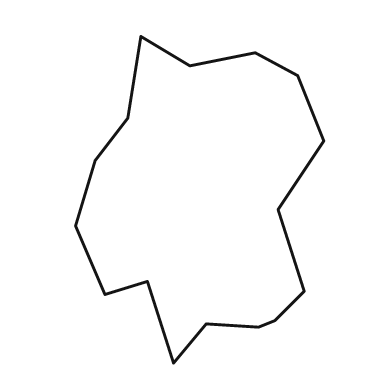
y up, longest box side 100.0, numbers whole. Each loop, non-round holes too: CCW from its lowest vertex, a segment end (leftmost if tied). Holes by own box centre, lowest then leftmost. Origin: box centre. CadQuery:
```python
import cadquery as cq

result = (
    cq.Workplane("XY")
    .moveTo(-8.0, -50.0)
    .lineTo(2.0, -38.0)
    .lineTo(18.0, -39.0)
    .lineTo(23.0, -37.0)
    .lineTo(32.0, -28.0)
    .lineTo(24.0, -3.0)
    .lineTo(38.0, 18.0)
    .lineTo(30.0, 38.0)
    .lineTo(17.0, 45.0)
    .lineTo(-3.0, 41.0)
    .lineTo(-18.0, 50.0)
    .lineTo(-22.0, 25.0)
    .lineTo(-32.0, 12.0)
    .lineTo(-38.0, -8.0)
    .lineTo(-29.0, -29.0)
    .lineTo(-16.0, -25.0)
    .close()
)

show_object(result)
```